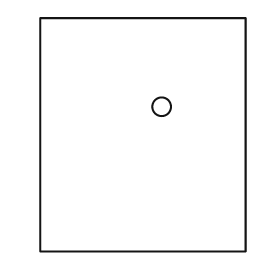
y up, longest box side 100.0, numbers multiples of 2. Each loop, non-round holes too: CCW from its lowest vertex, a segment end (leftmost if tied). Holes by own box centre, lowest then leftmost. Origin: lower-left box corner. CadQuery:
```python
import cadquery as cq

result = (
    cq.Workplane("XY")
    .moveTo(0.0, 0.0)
    .lineTo(88.0, 0.0)
    .lineTo(88.0, 100.0)
    .lineTo(0.0, 100.0)
    .close()
    .moveTo(52.0, 62.0)
    .circle(4.0)
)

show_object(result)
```